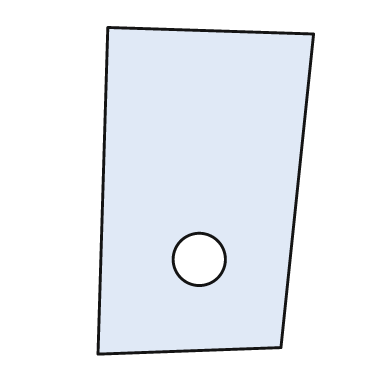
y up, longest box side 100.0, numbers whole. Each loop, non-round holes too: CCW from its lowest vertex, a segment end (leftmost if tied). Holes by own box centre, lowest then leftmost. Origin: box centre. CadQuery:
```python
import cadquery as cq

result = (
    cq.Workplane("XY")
    .moveTo(-33.0, -50.0)
    .lineTo(23.0, -48.0)
    .lineTo(33.0, 48.0)
    .lineTo(-30.0, 50.0)
    .close()
    .moveTo(-2.0, -21.0)
    .circle(8.0)
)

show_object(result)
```